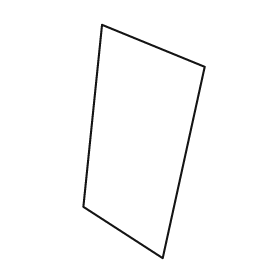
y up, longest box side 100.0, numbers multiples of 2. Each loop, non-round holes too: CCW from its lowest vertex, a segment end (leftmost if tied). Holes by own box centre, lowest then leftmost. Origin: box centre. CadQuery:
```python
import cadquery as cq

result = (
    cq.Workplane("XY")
    .moveTo(8.0, -50.0)
    .lineTo(26.0, 32.0)
    .lineTo(-18.0, 50.0)
    .lineTo(-26.0, -28.0)
    .close()
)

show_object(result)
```